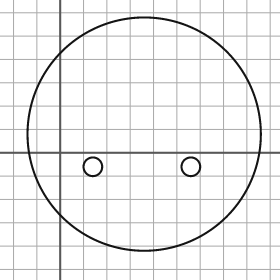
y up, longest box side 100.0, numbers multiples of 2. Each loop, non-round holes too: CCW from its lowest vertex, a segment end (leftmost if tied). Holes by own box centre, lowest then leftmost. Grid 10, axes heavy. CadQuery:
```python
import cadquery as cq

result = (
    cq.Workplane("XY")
    .moveTo(36.0, 8.0)
    .circle(50.0)
    .moveTo(14.0, -6.0)
    .circle(4.0)
    .moveTo(56.0, -6.0)
    .circle(4.0)
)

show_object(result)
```